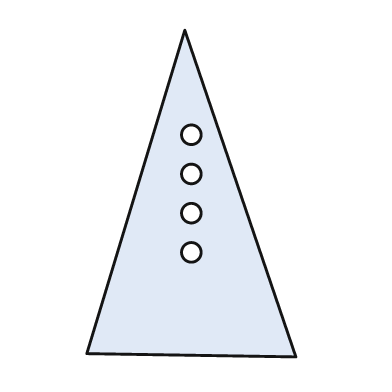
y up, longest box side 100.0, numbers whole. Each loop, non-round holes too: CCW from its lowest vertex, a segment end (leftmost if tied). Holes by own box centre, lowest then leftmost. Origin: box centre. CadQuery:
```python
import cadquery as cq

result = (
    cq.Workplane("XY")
    .moveTo(32.0, -50.0)
    .lineTo(-2.0, 50.0)
    .lineTo(-32.0, -49.0)
    .close()
    .moveTo(0.0, -18.0)
    .circle(3.0)
    .moveTo(0.0, -6.0)
    .circle(3.0)
    .moveTo(0.0, 6.0)
    .circle(3.0)
    .moveTo(0.0, 18.0)
    .circle(3.0)
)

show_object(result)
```